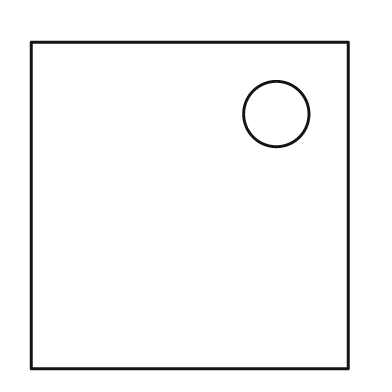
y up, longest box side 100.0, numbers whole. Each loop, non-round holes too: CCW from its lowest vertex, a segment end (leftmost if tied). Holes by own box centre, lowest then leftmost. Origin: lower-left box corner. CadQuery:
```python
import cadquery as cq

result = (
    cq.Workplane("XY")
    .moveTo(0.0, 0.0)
    .lineTo(97.0, 0.0)
    .lineTo(97.0, 100.0)
    .lineTo(0.0, 100.0)
    .close()
    .moveTo(75.0, 78.0)
    .circle(10.0)
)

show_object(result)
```